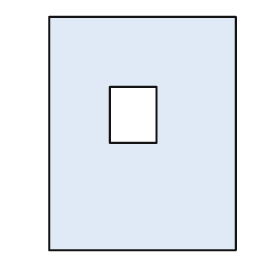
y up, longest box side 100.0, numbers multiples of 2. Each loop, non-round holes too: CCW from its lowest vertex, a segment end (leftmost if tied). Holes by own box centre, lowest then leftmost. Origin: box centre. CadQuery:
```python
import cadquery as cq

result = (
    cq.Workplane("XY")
    .moveTo(-40.0, -50.0)
    .lineTo(40.0, -50.0)
    .lineTo(40.0, 50.0)
    .lineTo(-40.0, 50.0)
    .close()
    .moveTo(-14.0, -4.0)
    .lineTo(6.0, -4.0)
    .lineTo(6.0, 20.0)
    .lineTo(-14.0, 20.0)
    .close()
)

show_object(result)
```